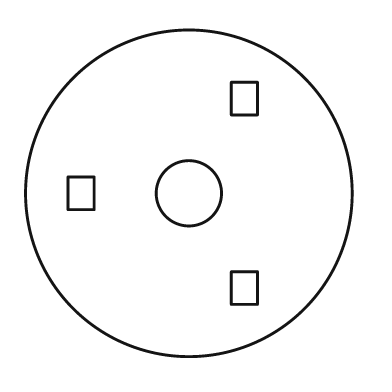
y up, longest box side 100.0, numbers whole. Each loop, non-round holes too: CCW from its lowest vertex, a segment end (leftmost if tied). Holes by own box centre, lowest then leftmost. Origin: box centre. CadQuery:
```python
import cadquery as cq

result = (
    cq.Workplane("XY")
    .moveTo(0.0, 0.0)
    .circle(50.0)
    .moveTo(13.0, -34.0)
    .lineTo(21.0, -34.0)
    .lineTo(21.0, -24.0)
    .lineTo(13.0, -24.0)
    .close()
    .moveTo(-37.0, -5.0)
    .lineTo(-29.0, -5.0)
    .lineTo(-29.0, 5.0)
    .lineTo(-37.0, 5.0)
    .close()
    .moveTo(0.0, 0.0)
    .circle(10.0)
    .moveTo(13.0, 24.0)
    .lineTo(21.0, 24.0)
    .lineTo(21.0, 34.0)
    .lineTo(13.0, 34.0)
    .close()
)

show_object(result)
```